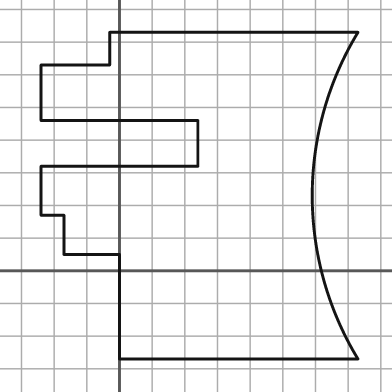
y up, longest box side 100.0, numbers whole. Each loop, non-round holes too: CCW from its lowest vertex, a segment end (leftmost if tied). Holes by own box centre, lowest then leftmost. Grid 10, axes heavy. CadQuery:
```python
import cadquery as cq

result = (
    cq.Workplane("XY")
    .moveTo(0.0, -27.0)
    .lineTo(73.0, -27.0)
    .threePointArc((59.0, 23.0), (73.0, 73.0))
    .lineTo(-3.0, 73.0)
    .lineTo(-3.0, 63.0)
    .lineTo(-24.0, 63.0)
    .lineTo(-24.0, 46.0)
    .lineTo(24.0, 46.0)
    .lineTo(24.0, 32.0)
    .lineTo(-24.0, 32.0)
    .lineTo(-24.0, 17.0)
    .lineTo(-17.0, 17.0)
    .lineTo(-17.0, 5.0)
    .lineTo(0.0, 5.0)
    .close()
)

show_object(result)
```